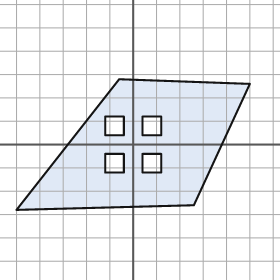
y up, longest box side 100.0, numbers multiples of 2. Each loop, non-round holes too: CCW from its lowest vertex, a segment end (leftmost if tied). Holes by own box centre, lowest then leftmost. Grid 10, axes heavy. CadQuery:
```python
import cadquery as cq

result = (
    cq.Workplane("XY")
    .moveTo(-50.0, -28.0)
    .lineTo(26.0, -26.0)
    .lineTo(50.0, 26.0)
    .lineTo(-6.0, 28.0)
    .close()
    .moveTo(-12.0, -12.0)
    .lineTo(-4.0, -12.0)
    .lineTo(-4.0, -4.0)
    .lineTo(-12.0, -4.0)
    .close()
    .moveTo(4.0, -12.0)
    .lineTo(12.0, -12.0)
    .lineTo(12.0, -4.0)
    .lineTo(4.0, -4.0)
    .close()
    .moveTo(-12.0, 4.0)
    .lineTo(-4.0, 4.0)
    .lineTo(-4.0, 12.0)
    .lineTo(-12.0, 12.0)
    .close()
    .moveTo(4.0, 4.0)
    .lineTo(12.0, 4.0)
    .lineTo(12.0, 12.0)
    .lineTo(4.0, 12.0)
    .close()
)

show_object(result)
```